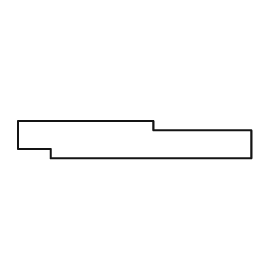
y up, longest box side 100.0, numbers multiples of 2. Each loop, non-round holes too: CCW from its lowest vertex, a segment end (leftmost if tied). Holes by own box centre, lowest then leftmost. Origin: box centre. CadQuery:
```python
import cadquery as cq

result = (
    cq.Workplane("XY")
    .moveTo(-36.0, -8.0)
    .lineTo(50.0, -8.0)
    .lineTo(50.0, 4.0)
    .lineTo(8.0, 4.0)
    .lineTo(8.0, 8.0)
    .lineTo(-50.0, 8.0)
    .lineTo(-50.0, -4.0)
    .lineTo(-36.0, -4.0)
    .close()
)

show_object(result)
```